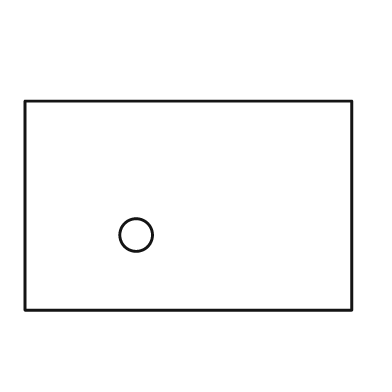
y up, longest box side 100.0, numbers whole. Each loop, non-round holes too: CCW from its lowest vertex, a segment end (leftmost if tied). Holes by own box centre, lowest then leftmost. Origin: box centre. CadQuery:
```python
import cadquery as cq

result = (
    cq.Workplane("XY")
    .moveTo(-50.0, -32.0)
    .lineTo(50.0, -32.0)
    .lineTo(50.0, 32.0)
    .lineTo(-50.0, 32.0)
    .close()
    .moveTo(-16.0, -9.0)
    .circle(5.0)
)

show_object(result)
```